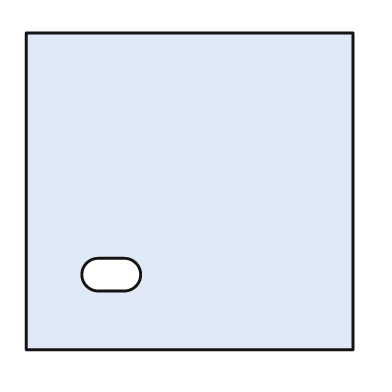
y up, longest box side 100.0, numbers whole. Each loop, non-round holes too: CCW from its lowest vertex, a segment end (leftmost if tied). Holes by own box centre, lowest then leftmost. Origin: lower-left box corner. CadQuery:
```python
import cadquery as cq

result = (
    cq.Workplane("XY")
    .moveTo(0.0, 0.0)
    .lineTo(100.0, 0.0)
    .lineTo(100.0, 97.0)
    .lineTo(0.0, 97.0)
    .close()
    .moveTo(22.0, 18.0)
    .lineTo(30.0, 18.0)
    .threePointArc((35.0, 23.0), (30.0, 28.0))
    .lineTo(22.0, 28.0)
    .threePointArc((17.0, 23.0), (22.0, 18.0))
    .close()
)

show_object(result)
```